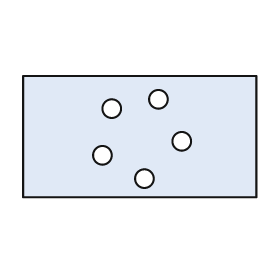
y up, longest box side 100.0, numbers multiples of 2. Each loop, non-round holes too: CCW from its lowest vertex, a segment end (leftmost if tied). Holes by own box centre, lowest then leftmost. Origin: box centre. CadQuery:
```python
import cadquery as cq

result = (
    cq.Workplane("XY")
    .moveTo(-50.0, -26.0)
    .lineTo(50.0, -26.0)
    .lineTo(50.0, 26.0)
    .lineTo(-50.0, 26.0)
    .close()
    .moveTo(2.0, -18.0)
    .circle(4.0)
    .moveTo(-16.0, -8.0)
    .circle(4.0)
    .moveTo(18.0, -2.0)
    .circle(4.0)
    .moveTo(-12.0, 12.0)
    .circle(4.0)
    .moveTo(8.0, 16.0)
    .circle(4.0)
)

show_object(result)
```